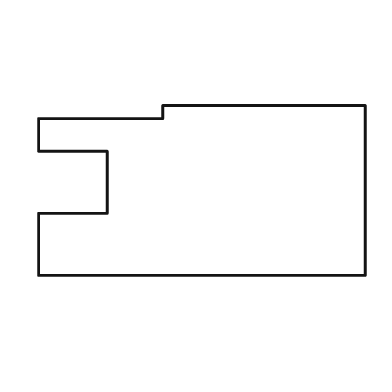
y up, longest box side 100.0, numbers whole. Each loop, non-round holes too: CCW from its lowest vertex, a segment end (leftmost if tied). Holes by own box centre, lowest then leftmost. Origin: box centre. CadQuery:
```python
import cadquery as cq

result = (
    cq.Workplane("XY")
    .moveTo(-50.0, -26.0)
    .lineTo(50.0, -26.0)
    .lineTo(50.0, 26.0)
    .lineTo(-12.0, 26.0)
    .lineTo(-12.0, 22.0)
    .lineTo(-50.0, 22.0)
    .lineTo(-50.0, 12.0)
    .lineTo(-29.0, 12.0)
    .lineTo(-29.0, -7.0)
    .lineTo(-50.0, -7.0)
    .close()
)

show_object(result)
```